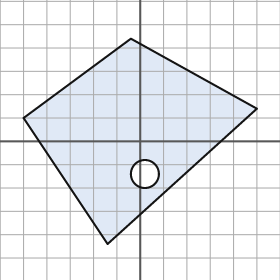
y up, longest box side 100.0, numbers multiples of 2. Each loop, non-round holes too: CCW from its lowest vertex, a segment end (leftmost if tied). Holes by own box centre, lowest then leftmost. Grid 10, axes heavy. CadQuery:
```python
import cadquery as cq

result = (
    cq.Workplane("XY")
    .moveTo(-14.0, -44.0)
    .lineTo(50.0, 14.0)
    .lineTo(-4.0, 44.0)
    .lineTo(-50.0, 10.0)
    .close()
    .moveTo(2.0, -14.0)
    .circle(6.0)
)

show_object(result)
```